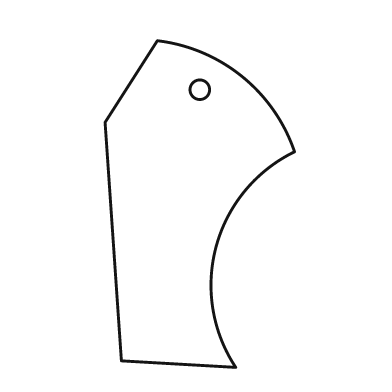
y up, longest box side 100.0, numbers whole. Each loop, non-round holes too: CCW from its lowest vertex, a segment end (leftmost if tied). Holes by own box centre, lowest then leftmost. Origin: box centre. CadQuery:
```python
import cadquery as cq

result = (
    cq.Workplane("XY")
    .moveTo(11.0, -50.0)
    .threePointArc((5.0, -13.0), (29.0, 16.0))
    .threePointArc((13.0, 39.0), (-13.0, 50.0))
    .lineTo(-29.0, 25.0)
    .lineTo(-24.0, -48.0)
    .close()
    .moveTo(0.0, 35.0)
    .circle(3.0)
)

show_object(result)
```